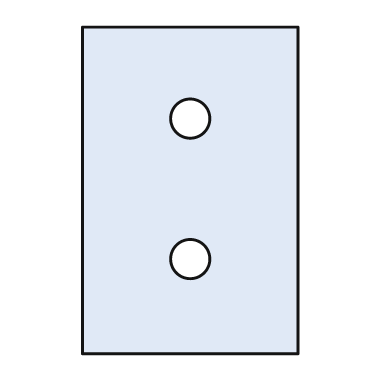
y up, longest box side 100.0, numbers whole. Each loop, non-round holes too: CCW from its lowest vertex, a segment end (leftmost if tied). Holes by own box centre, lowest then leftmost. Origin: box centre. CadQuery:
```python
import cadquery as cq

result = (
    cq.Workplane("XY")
    .moveTo(-33.0, -50.0)
    .lineTo(33.0, -50.0)
    .lineTo(33.0, 50.0)
    .lineTo(-33.0, 50.0)
    .close()
    .moveTo(0.0, -21.0)
    .circle(6.0)
    .moveTo(0.0, 22.0)
    .circle(6.0)
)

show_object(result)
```